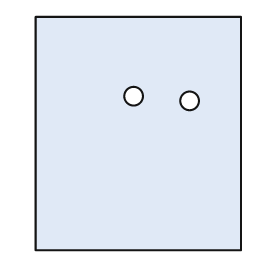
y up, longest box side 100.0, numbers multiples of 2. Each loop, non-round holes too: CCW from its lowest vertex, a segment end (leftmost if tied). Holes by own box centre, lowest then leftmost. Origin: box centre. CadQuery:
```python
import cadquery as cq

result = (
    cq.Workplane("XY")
    .moveTo(-44.0, -50.0)
    .lineTo(44.0, -50.0)
    .lineTo(44.0, 50.0)
    .lineTo(-44.0, 50.0)
    .close()
    .moveTo(22.0, 14.0)
    .circle(4.0)
    .moveTo(-2.0, 16.0)
    .circle(4.0)
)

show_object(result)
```